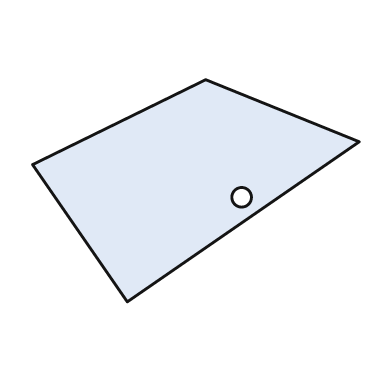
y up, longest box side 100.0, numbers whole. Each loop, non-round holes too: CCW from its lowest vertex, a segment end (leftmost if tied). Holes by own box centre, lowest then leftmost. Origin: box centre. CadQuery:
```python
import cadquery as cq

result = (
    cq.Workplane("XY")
    .moveTo(-21.0, -34.0)
    .lineTo(50.0, 15.0)
    .lineTo(3.0, 34.0)
    .lineTo(-50.0, 8.0)
    .close()
    .moveTo(14.0, -2.0)
    .circle(3.0)
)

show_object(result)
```